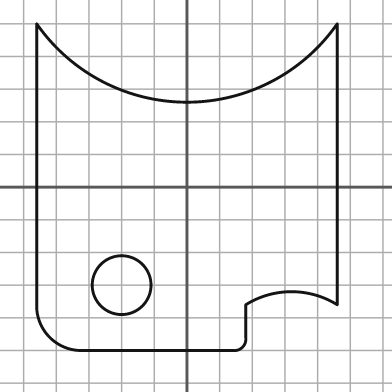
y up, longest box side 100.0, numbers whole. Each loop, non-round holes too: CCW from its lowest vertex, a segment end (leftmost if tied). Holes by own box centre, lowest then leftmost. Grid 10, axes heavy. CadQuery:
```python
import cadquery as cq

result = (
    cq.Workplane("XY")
    .moveTo(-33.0, -50.0)
    .lineTo(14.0, -50.0)
    .threePointArc((17.0, -49.0), (18.0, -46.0))
    .lineTo(18.0, -36.0)
    .threePointArc((32.0, -32.0), (46.0, -36.0))
    .lineTo(46.0, 50.0)
    .threePointArc((0.0, 26.0), (-46.0, 50.0))
    .lineTo(-46.0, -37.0)
    .threePointArc((-42.0, -46.0), (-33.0, -50.0))
    .close()
    .moveTo(-20.0, -30.0)
    .circle(9.0)
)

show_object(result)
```